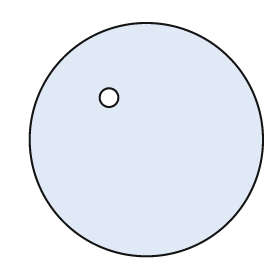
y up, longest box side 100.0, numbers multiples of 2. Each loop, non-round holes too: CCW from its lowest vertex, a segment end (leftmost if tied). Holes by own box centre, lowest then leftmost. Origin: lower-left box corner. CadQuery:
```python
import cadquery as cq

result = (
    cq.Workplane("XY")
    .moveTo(50.0, 50.0)
    .circle(50.0)
    .moveTo(34.0, 68.0)
    .circle(4.0)
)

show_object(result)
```